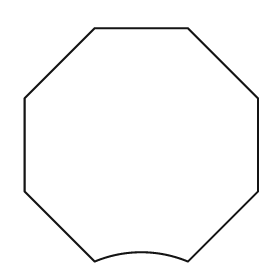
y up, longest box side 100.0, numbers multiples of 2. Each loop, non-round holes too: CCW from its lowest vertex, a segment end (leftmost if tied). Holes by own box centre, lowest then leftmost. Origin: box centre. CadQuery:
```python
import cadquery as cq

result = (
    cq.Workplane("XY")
    .moveTo(-20.0, -50.0)
    .threePointArc((0.0, -46.0), (20.0, -50.0))
    .lineTo(50.0, -20.0)
    .lineTo(50.0, 20.0)
    .lineTo(20.0, 50.0)
    .lineTo(-20.0, 50.0)
    .lineTo(-50.0, 20.0)
    .lineTo(-50.0, -20.0)
    .close()
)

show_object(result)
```